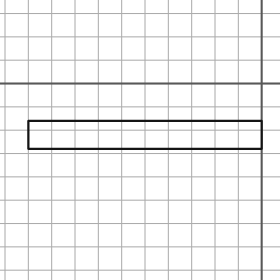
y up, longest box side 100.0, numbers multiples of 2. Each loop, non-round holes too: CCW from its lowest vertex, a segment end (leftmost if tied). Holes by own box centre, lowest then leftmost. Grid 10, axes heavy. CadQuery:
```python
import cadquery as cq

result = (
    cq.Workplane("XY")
    .moveTo(-100.0, -28.0)
    .lineTo(0.0, -28.0)
    .lineTo(0.0, -16.0)
    .lineTo(-100.0, -16.0)
    .close()
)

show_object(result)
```